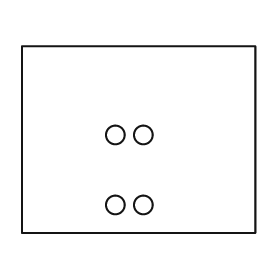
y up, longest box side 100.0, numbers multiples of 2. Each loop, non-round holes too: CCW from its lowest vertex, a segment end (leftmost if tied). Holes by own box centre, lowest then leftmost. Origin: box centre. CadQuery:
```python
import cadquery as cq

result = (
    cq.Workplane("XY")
    .moveTo(-50.0, -40.0)
    .lineTo(50.0, -40.0)
    .lineTo(50.0, 40.0)
    .lineTo(-50.0, 40.0)
    .close()
    .moveTo(-10.0, -28.0)
    .circle(4.0)
    .moveTo(2.0, -28.0)
    .circle(4.0)
    .moveTo(-10.0, 2.0)
    .circle(4.0)
    .moveTo(2.0, 2.0)
    .circle(4.0)
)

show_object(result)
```